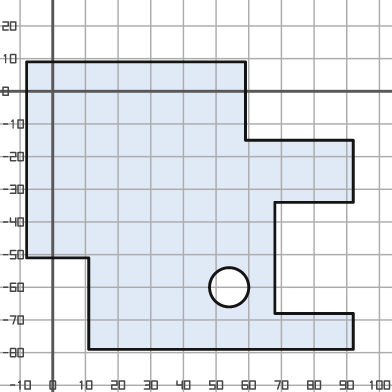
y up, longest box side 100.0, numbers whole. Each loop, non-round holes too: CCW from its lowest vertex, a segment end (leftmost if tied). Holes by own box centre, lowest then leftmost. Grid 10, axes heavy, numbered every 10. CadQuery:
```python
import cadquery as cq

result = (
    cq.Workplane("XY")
    .moveTo(11.0, -79.0)
    .lineTo(92.0, -79.0)
    .lineTo(92.0, -68.0)
    .lineTo(68.0, -68.0)
    .lineTo(68.0, -34.0)
    .lineTo(92.0, -34.0)
    .lineTo(92.0, -15.0)
    .lineTo(59.0, -15.0)
    .lineTo(59.0, 9.0)
    .lineTo(-8.0, 9.0)
    .lineTo(-8.0, -51.0)
    .lineTo(11.0, -51.0)
    .close()
    .moveTo(54.0, -60.0)
    .circle(6.0)
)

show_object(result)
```